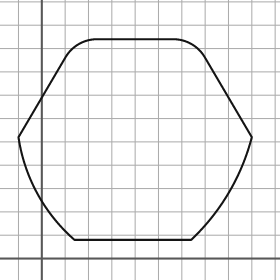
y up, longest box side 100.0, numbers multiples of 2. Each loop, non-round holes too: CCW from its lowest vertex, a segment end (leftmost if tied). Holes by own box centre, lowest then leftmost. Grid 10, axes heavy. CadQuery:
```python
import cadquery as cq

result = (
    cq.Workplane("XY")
    .moveTo(14.0, 8.0)
    .lineTo(64.0, 8.0)
    .threePointArc((80.0, 28.0), (90.0, 52.0))
    .lineTo(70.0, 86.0)
    .threePointArc((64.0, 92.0), (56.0, 94.0))
    .lineTo(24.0, 94.0)
    .threePointArc((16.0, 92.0), (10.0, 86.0))
    .lineTo(-10.0, 52.0)
    .threePointArc((-2.0, 28.0), (14.0, 8.0))
    .close()
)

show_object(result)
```